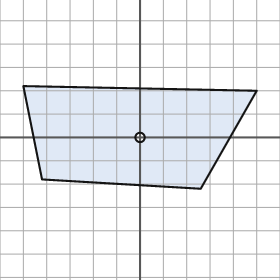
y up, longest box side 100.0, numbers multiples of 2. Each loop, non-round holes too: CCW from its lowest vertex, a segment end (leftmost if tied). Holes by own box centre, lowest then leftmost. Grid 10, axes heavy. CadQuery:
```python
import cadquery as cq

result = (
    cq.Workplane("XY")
    .moveTo(26.0, -22.0)
    .lineTo(50.0, 20.0)
    .lineTo(-50.0, 22.0)
    .lineTo(-42.0, -18.0)
    .close()
    .moveTo(0.0, 0.0)
    .circle(2.0)
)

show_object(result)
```